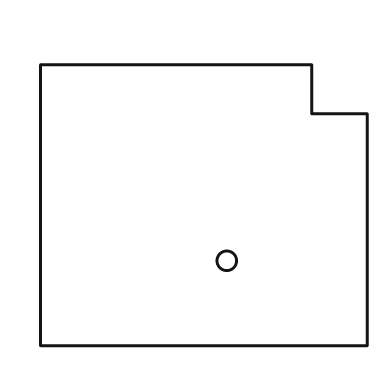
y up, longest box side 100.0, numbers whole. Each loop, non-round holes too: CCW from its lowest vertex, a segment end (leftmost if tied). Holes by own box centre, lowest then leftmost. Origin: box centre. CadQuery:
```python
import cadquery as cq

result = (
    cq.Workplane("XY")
    .moveTo(-50.0, -43.0)
    .lineTo(50.0, -43.0)
    .lineTo(50.0, 28.0)
    .lineTo(33.0, 28.0)
    .lineTo(33.0, 43.0)
    .lineTo(-50.0, 43.0)
    .close()
    .moveTo(7.0, -17.0)
    .circle(3.0)
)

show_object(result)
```